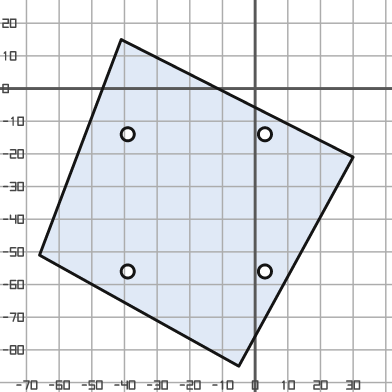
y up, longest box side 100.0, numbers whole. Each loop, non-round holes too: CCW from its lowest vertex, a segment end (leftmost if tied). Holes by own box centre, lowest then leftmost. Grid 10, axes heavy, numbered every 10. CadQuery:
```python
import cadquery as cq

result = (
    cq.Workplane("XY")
    .moveTo(-5.0, -85.0)
    .lineTo(30.0, -21.0)
    .lineTo(-41.0, 15.0)
    .lineTo(-66.0, -51.0)
    .close()
    .moveTo(-39.0, -56.0)
    .circle(2.0)
    .moveTo(3.0, -56.0)
    .circle(2.0)
    .moveTo(-39.0, -14.0)
    .circle(2.0)
    .moveTo(3.0, -14.0)
    .circle(2.0)
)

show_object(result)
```